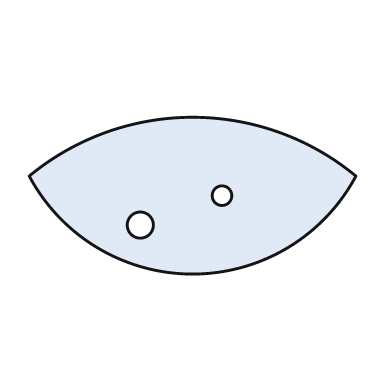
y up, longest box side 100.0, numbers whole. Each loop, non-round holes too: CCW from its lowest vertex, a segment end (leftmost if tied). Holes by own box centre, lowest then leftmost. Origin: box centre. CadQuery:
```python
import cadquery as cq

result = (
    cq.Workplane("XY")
    .moveTo(-50.0, 6.0)
    .threePointArc((0.0, -24.0), (50.0, 6.0))
    .threePointArc((0.0, 24.0), (-50.0, 6.0))
    .close()
    .moveTo(-16.0, -9.0)
    .circle(4.0)
    .moveTo(9.0, 0.0)
    .circle(3.0)
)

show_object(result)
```